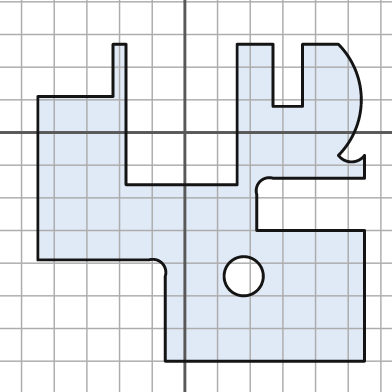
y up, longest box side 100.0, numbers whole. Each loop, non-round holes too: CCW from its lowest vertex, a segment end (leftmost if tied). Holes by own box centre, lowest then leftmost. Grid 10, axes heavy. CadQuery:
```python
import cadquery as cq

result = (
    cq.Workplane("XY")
    .moveTo(-6.0, -70.0)
    .lineTo(55.0, -70.0)
    .lineTo(55.0, -30.0)
    .lineTo(22.0, -30.0)
    .lineTo(22.0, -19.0)
    .threePointArc((23.0, -15.0), (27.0, -14.0))
    .lineTo(55.0, -14.0)
    .lineTo(55.0, -7.0)
    .threePointArc((51.0, -9.0), (47.0, -7.0))
    .threePointArc((54.0, 10.0), (47.0, 27.0))
    .lineTo(36.0, 27.0)
    .lineTo(36.0, 8.0)
    .lineTo(27.0, 8.0)
    .lineTo(27.0, 27.0)
    .lineTo(16.0, 27.0)
    .lineTo(16.0, -16.0)
    .lineTo(-18.0, -16.0)
    .lineTo(-18.0, 27.0)
    .lineTo(-22.0, 27.0)
    .lineTo(-22.0, 11.0)
    .lineTo(-45.0, 11.0)
    .lineTo(-45.0, -39.0)
    .lineTo(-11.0, -39.0)
    .threePointArc((-7.0, -40.0), (-6.0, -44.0))
    .close()
    .moveTo(18.0, -44.0)
    .circle(6.0)
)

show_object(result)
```